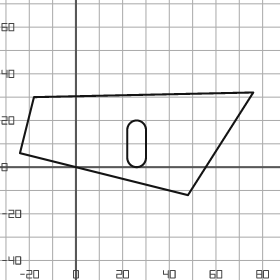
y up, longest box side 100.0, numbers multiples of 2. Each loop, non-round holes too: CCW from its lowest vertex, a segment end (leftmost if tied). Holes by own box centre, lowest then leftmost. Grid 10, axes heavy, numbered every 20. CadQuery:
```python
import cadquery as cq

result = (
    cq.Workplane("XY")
    .moveTo(48.0, -12.0)
    .lineTo(76.0, 32.0)
    .lineTo(-18.0, 30.0)
    .lineTo(-24.0, 6.0)
    .close()
    .moveTo(22.0, 4.0)
    .threePointArc((26.0, 0.0), (30.0, 4.0))
    .lineTo(30.0, 16.0)
    .threePointArc((26.0, 20.0), (22.0, 16.0))
    .close()
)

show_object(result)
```